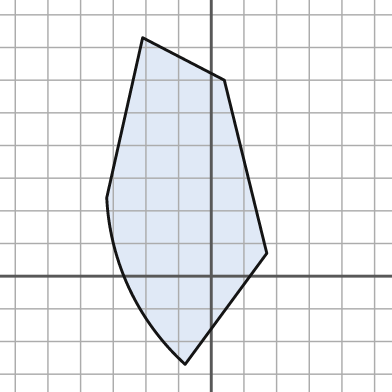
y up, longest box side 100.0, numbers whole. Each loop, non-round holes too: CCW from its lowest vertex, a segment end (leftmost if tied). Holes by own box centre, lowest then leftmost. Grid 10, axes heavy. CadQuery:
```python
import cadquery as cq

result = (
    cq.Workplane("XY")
    .moveTo(-8.0, -27.0)
    .lineTo(17.0, 7.0)
    .lineTo(4.0, 60.0)
    .lineTo(-21.0, 73.0)
    .lineTo(-32.0, 24.0)
    .threePointArc((-25.0, -4.0), (-8.0, -27.0))
    .close()
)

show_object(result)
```